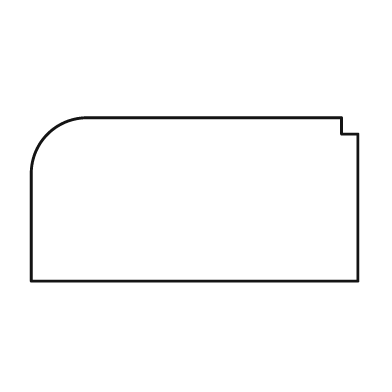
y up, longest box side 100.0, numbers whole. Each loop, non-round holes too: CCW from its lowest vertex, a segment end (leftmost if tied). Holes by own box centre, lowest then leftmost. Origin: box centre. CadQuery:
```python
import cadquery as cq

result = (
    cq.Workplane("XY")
    .moveTo(-50.0, -25.0)
    .lineTo(50.0, -25.0)
    .lineTo(50.0, 20.0)
    .lineTo(45.0, 20.0)
    .lineTo(45.0, 25.0)
    .lineTo(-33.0, 25.0)
    .threePointArc((-45.0, 20.0), (-50.0, 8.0))
    .close()
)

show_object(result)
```